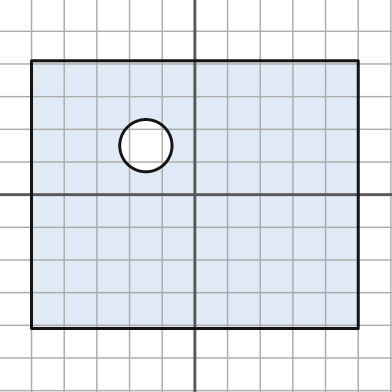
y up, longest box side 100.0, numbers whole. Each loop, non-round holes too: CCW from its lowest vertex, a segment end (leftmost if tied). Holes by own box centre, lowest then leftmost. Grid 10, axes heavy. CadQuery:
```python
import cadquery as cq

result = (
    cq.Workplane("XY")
    .moveTo(-50.0, -41.0)
    .lineTo(50.0, -41.0)
    .lineTo(50.0, 41.0)
    .lineTo(-50.0, 41.0)
    .close()
    .moveTo(-15.0, 15.0)
    .circle(8.0)
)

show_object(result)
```